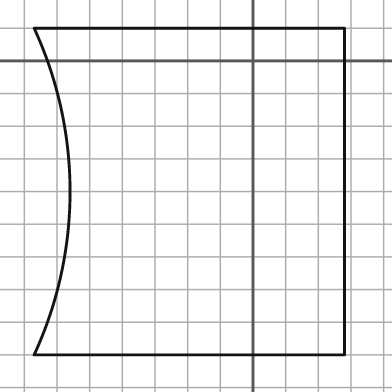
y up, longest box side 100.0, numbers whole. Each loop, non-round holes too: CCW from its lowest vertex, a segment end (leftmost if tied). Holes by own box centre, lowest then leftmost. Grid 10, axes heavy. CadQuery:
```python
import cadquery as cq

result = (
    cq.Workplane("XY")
    .moveTo(-67.0, -90.0)
    .lineTo(28.0, -90.0)
    .lineTo(28.0, 10.0)
    .lineTo(-67.0, 10.0)
    .threePointArc((-56.0, -40.0), (-67.0, -90.0))
    .close()
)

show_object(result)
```